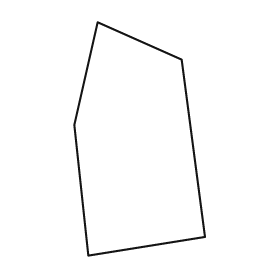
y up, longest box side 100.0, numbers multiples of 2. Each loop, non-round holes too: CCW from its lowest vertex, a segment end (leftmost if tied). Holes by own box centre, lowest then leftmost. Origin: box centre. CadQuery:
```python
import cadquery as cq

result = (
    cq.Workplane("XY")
    .moveTo(-22.0, -50.0)
    .lineTo(28.0, -42.0)
    .lineTo(18.0, 34.0)
    .lineTo(-18.0, 50.0)
    .lineTo(-28.0, 6.0)
    .close()
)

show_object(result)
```